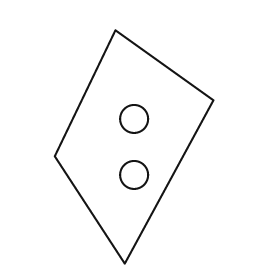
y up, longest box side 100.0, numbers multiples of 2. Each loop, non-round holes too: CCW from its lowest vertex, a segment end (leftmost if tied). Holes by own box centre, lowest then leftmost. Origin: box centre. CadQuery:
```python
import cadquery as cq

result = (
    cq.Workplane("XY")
    .moveTo(-4.0, -50.0)
    .lineTo(34.0, 20.0)
    .lineTo(-8.0, 50.0)
    .lineTo(-34.0, -4.0)
    .close()
    .moveTo(0.0, -12.0)
    .circle(6.0)
    .moveTo(0.0, 12.0)
    .circle(6.0)
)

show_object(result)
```